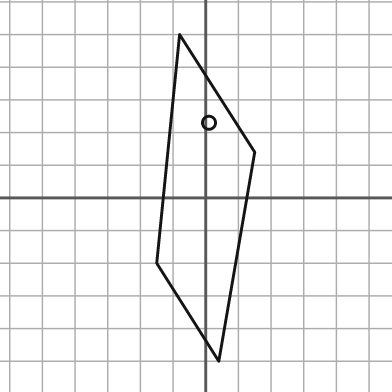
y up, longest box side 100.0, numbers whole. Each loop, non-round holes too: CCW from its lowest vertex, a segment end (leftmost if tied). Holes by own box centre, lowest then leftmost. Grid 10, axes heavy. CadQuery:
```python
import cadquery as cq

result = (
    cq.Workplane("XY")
    .moveTo(4.0, -50.0)
    .lineTo(15.0, 14.0)
    .lineTo(-8.0, 50.0)
    .lineTo(-15.0, -20.0)
    .close()
    .moveTo(1.0, 23.0)
    .circle(2.0)
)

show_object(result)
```